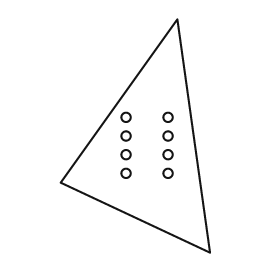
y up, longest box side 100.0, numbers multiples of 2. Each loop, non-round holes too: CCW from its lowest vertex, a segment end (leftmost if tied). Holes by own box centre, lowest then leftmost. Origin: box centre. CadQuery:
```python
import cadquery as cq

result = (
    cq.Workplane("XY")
    .moveTo(32.0, -50.0)
    .lineTo(18.0, 50.0)
    .lineTo(-32.0, -20.0)
    .close()
    .moveTo(-4.0, -16.0)
    .circle(2.0)
    .moveTo(14.0, -16.0)
    .circle(2.0)
    .moveTo(-4.0, -8.0)
    .circle(2.0)
    .moveTo(14.0, -8.0)
    .circle(2.0)
    .moveTo(-4.0, 0.0)
    .circle(2.0)
    .moveTo(14.0, 0.0)
    .circle(2.0)
    .moveTo(-4.0, 8.0)
    .circle(2.0)
    .moveTo(14.0, 8.0)
    .circle(2.0)
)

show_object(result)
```